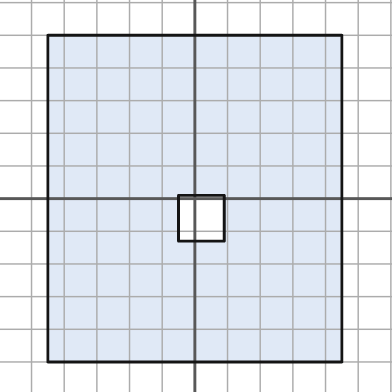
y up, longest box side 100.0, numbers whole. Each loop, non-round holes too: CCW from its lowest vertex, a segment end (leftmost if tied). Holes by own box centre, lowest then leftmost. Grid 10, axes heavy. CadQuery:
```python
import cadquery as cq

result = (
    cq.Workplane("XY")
    .moveTo(-45.0, -50.0)
    .lineTo(45.0, -50.0)
    .lineTo(45.0, 50.0)
    .lineTo(-45.0, 50.0)
    .close()
    .moveTo(-5.0, -13.0)
    .lineTo(9.0, -13.0)
    .lineTo(9.0, 1.0)
    .lineTo(-5.0, 1.0)
    .close()
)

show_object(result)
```